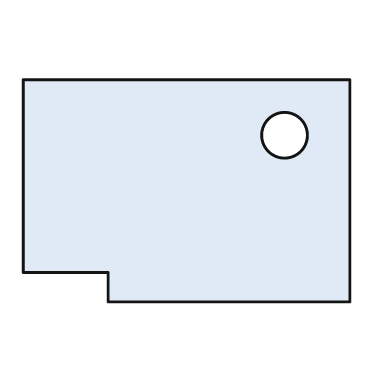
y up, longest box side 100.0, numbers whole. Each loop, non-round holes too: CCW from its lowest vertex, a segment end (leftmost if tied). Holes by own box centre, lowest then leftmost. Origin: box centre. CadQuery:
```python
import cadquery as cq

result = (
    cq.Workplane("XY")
    .moveTo(-24.0, -34.0)
    .lineTo(50.0, -34.0)
    .lineTo(50.0, 34.0)
    .lineTo(-50.0, 34.0)
    .lineTo(-50.0, -25.0)
    .lineTo(-24.0, -25.0)
    .close()
    .moveTo(30.0, 17.0)
    .circle(7.0)
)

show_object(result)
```